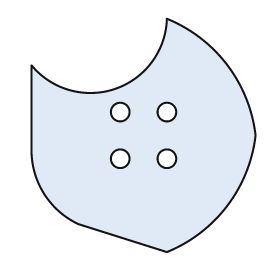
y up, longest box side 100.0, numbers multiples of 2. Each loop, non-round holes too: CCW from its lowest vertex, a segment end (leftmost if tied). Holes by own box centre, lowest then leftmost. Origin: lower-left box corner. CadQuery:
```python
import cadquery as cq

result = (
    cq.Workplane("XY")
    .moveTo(58.0, 0.0)
    .threePointArc((84.0, 20.0), (96.0, 50.0))
    .threePointArc((84.0, 80.0), (58.0, 100.0))
    .threePointArc((36.0, 70.0), (0.0, 80.0))
    .lineTo(0.0, 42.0)
    .threePointArc((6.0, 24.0), (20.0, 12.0))
    .close()
    .moveTo(38.0, 40.0)
    .circle(4.0)
    .moveTo(58.0, 40.0)
    .circle(4.0)
    .moveTo(38.0, 60.0)
    .circle(4.0)
    .moveTo(58.0, 60.0)
    .circle(4.0)
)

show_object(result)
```